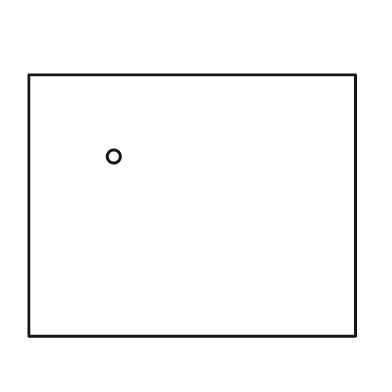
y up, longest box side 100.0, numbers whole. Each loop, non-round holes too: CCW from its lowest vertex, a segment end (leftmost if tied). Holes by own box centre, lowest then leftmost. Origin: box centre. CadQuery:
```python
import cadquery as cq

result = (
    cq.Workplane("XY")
    .moveTo(-50.0, -40.0)
    .lineTo(50.0, -40.0)
    .lineTo(50.0, 40.0)
    .lineTo(-50.0, 40.0)
    .close()
    .moveTo(-24.0, 15.0)
    .circle(2.0)
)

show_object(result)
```